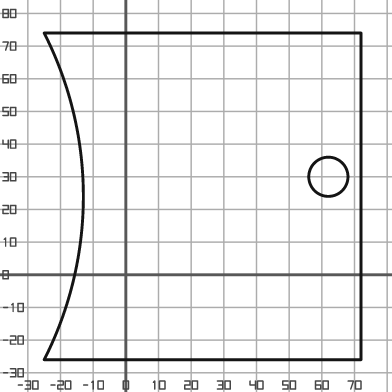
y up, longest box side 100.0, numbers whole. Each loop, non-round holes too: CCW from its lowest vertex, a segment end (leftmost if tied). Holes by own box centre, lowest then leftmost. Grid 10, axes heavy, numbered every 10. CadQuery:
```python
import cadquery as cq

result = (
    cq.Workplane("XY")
    .moveTo(-25.0, -26.0)
    .lineTo(72.0, -26.0)
    .lineTo(72.0, 74.0)
    .lineTo(-25.0, 74.0)
    .threePointArc((-13.0, 24.0), (-25.0, -26.0))
    .close()
    .moveTo(62.0, 30.0)
    .circle(6.0)
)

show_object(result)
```